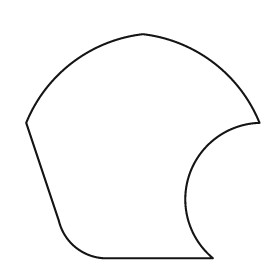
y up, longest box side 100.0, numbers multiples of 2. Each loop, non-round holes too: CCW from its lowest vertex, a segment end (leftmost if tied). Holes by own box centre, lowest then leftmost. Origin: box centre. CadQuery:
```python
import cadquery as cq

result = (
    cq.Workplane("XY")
    .moveTo(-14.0, -48.0)
    .lineTo(30.0, -48.0)
    .threePointArc((20.0, -12.0), (50.0, 10.0))
    .threePointArc((30.0, 36.0), (0.0, 48.0))
    .threePointArc((-30.0, 36.0), (-50.0, 10.0))
    .lineTo(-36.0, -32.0)
    .threePointArc((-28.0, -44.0), (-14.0, -48.0))
    .close()
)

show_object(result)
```